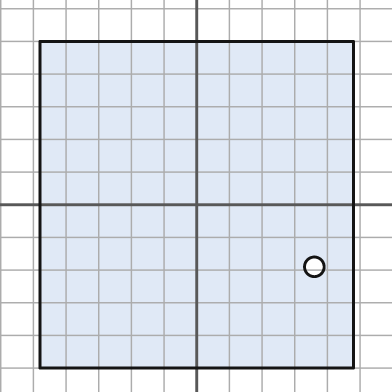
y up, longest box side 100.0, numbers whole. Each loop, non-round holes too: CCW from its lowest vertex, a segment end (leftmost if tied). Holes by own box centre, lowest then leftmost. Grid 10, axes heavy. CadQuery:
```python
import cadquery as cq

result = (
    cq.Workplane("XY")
    .moveTo(-48.0, -50.0)
    .lineTo(48.0, -50.0)
    .lineTo(48.0, 50.0)
    .lineTo(-48.0, 50.0)
    .close()
    .moveTo(36.0, -19.0)
    .circle(3.0)
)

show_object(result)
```